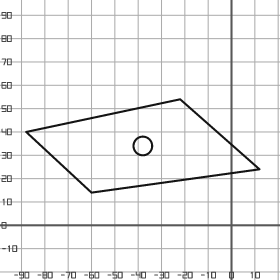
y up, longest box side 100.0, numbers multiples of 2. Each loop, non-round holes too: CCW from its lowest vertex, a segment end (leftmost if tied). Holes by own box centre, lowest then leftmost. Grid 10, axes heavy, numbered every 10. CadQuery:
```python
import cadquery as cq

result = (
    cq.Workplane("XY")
    .moveTo(-60.0, 14.0)
    .lineTo(12.0, 24.0)
    .lineTo(-22.0, 54.0)
    .lineTo(-88.0, 40.0)
    .close()
    .moveTo(-38.0, 34.0)
    .circle(4.0)
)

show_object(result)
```